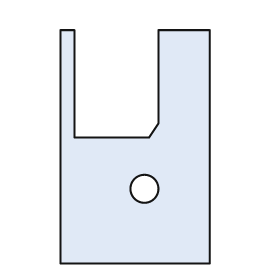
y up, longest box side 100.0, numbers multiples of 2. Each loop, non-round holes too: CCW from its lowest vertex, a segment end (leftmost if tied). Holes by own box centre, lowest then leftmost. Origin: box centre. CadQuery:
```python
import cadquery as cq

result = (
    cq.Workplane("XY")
    .moveTo(-32.0, -50.0)
    .lineTo(32.0, -50.0)
    .lineTo(32.0, 50.0)
    .lineTo(10.0, 50.0)
    .lineTo(10.0, 10.0)
    .lineTo(6.0, 4.0)
    .lineTo(-26.0, 4.0)
    .lineTo(-26.0, 50.0)
    .lineTo(-32.0, 50.0)
    .close()
    .moveTo(4.0, -18.0)
    .circle(6.0)
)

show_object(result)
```